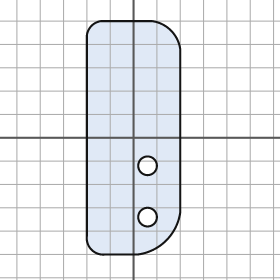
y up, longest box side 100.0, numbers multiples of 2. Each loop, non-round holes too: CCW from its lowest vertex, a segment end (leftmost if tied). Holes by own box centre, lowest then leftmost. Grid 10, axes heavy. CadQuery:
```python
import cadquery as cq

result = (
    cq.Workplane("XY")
    .moveTo(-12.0, -50.0)
    .lineTo(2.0, -50.0)
    .threePointArc((14.0, -44.0), (20.0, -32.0))
    .lineTo(20.0, 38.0)
    .threePointArc((16.0, 46.0), (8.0, 50.0))
    .lineTo(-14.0, 50.0)
    .threePointArc((-18.0, 48.0), (-20.0, 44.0))
    .lineTo(-20.0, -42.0)
    .threePointArc((-18.0, -48.0), (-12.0, -50.0))
    .close()
    .moveTo(6.0, -34.0)
    .circle(4.0)
    .moveTo(6.0, -12.0)
    .circle(4.0)
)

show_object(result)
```